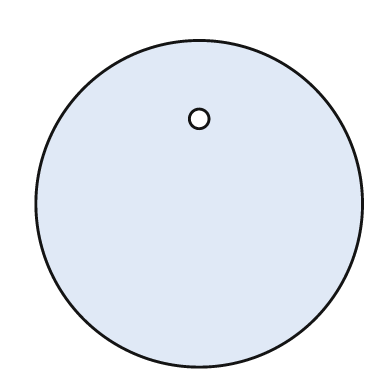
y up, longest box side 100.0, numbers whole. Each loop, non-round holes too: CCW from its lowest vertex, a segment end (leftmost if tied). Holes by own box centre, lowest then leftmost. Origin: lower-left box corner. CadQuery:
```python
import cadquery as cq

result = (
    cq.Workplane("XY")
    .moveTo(50.0, 50.0)
    .circle(50.0)
    .moveTo(50.0, 76.0)
    .circle(3.0)
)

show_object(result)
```